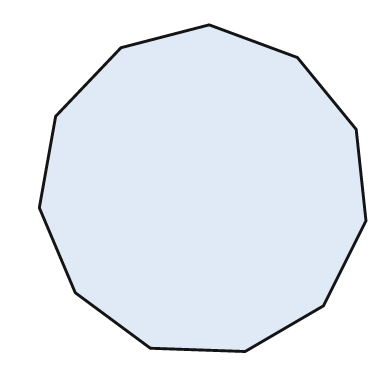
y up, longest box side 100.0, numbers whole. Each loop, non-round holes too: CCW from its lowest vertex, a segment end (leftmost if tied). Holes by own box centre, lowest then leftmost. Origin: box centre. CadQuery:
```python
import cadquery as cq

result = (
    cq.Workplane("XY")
    .moveTo(13.0, -50.0)
    .lineTo(37.0, -36.0)
    .lineTo(50.0, -10.0)
    .lineTo(47.0, 18.0)
    .lineTo(29.0, 40.0)
    .lineTo(2.0, 50.0)
    .lineTo(-25.0, 43.0)
    .lineTo(-45.0, 22.0)
    .lineTo(-50.0, -6.0)
    .lineTo(-39.0, -32.0)
    .lineTo(-16.0, -49.0)
    .close()
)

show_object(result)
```